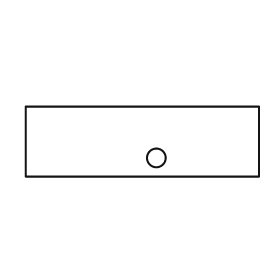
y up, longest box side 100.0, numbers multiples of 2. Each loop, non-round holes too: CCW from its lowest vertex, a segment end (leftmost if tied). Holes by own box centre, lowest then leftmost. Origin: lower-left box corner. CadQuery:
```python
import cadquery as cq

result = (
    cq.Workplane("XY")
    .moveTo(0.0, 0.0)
    .lineTo(100.0, 0.0)
    .lineTo(100.0, 30.0)
    .lineTo(0.0, 30.0)
    .close()
    .moveTo(56.0, 8.0)
    .circle(4.0)
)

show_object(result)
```